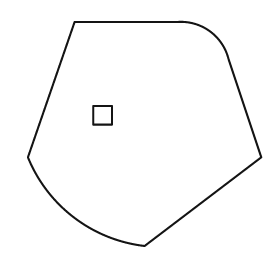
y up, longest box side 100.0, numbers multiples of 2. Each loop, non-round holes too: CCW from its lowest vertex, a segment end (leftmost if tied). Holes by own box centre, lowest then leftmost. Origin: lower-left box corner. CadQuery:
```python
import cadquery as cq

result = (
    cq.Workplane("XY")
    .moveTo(50.0, 0.0)
    .lineTo(100.0, 38.0)
    .lineTo(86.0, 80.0)
    .threePointArc((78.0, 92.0), (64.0, 96.0))
    .lineTo(20.0, 96.0)
    .lineTo(0.0, 38.0)
    .threePointArc((20.0, 12.0), (50.0, 0.0))
    .close()
    .moveTo(28.0, 52.0)
    .lineTo(36.0, 52.0)
    .lineTo(36.0, 60.0)
    .lineTo(28.0, 60.0)
    .close()
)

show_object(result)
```